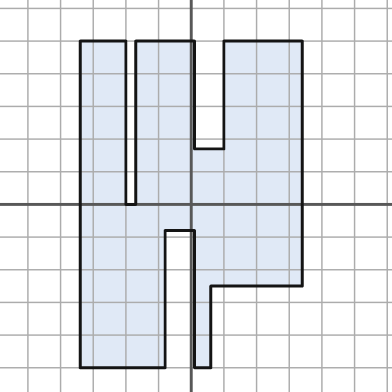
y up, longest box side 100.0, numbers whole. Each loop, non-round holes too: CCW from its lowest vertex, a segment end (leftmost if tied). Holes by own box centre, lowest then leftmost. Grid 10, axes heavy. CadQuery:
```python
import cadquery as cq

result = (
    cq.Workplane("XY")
    .moveTo(-34.0, -50.0)
    .lineTo(-8.0, -50.0)
    .lineTo(-8.0, -8.0)
    .lineTo(1.0, -8.0)
    .lineTo(1.0, -50.0)
    .lineTo(6.0, -50.0)
    .lineTo(6.0, -25.0)
    .lineTo(34.0, -25.0)
    .lineTo(34.0, 50.0)
    .lineTo(10.0, 50.0)
    .lineTo(10.0, 17.0)
    .lineTo(1.0, 17.0)
    .lineTo(1.0, 50.0)
    .lineTo(-17.0, 50.0)
    .lineTo(-17.0, 0.0)
    .lineTo(-20.0, 0.0)
    .lineTo(-20.0, 50.0)
    .lineTo(-34.0, 50.0)
    .close()
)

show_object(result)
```